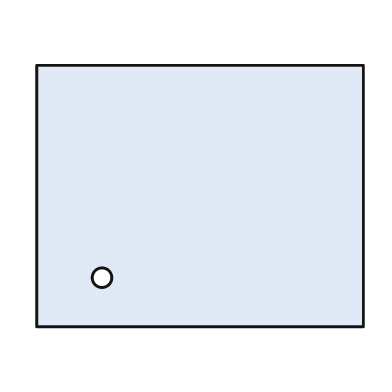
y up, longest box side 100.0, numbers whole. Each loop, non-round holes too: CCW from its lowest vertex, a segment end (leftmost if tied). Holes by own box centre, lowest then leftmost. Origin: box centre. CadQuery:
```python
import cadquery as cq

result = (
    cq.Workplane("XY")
    .moveTo(-50.0, -40.0)
    .lineTo(50.0, -40.0)
    .lineTo(50.0, 40.0)
    .lineTo(-50.0, 40.0)
    .close()
    .moveTo(-30.0, -25.0)
    .circle(3.0)
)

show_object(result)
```